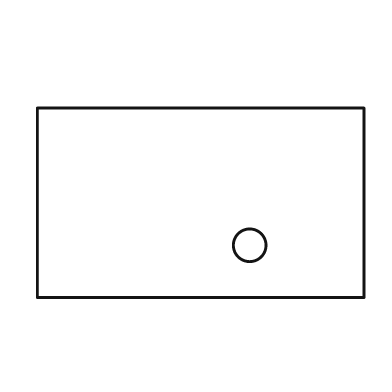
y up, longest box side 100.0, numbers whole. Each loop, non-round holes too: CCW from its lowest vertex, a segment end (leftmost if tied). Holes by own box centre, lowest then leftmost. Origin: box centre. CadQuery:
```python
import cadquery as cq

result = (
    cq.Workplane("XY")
    .moveTo(-50.0, -29.0)
    .lineTo(50.0, -29.0)
    .lineTo(50.0, 29.0)
    .lineTo(-50.0, 29.0)
    .close()
    .moveTo(15.0, -13.0)
    .circle(5.0)
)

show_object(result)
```